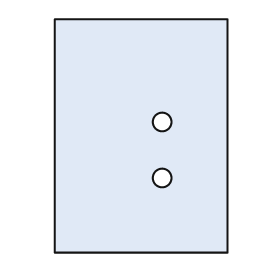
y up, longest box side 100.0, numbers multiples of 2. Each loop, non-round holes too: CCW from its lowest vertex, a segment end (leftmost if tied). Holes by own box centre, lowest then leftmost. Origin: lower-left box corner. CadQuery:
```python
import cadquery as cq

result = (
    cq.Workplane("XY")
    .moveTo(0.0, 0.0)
    .lineTo(74.0, 0.0)
    .lineTo(74.0, 100.0)
    .lineTo(0.0, 100.0)
    .close()
    .moveTo(46.0, 32.0)
    .circle(4.0)
    .moveTo(46.0, 56.0)
    .circle(4.0)
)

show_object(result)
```